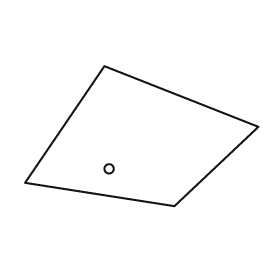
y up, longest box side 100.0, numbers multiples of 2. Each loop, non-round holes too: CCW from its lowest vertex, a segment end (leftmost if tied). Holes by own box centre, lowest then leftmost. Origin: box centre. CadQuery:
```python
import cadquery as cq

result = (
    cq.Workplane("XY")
    .moveTo(14.0, -30.0)
    .lineTo(50.0, 4.0)
    .lineTo(-16.0, 30.0)
    .lineTo(-50.0, -20.0)
    .close()
    .moveTo(-14.0, -14.0)
    .circle(2.0)
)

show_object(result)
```